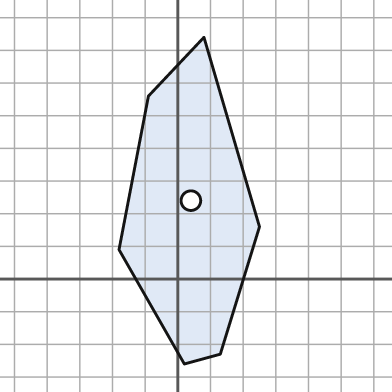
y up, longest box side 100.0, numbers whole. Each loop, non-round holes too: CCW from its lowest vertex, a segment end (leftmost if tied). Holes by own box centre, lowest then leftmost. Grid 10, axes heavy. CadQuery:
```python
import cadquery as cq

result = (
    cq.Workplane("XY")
    .moveTo(2.0, -26.0)
    .lineTo(13.0, -23.0)
    .lineTo(25.0, 16.0)
    .lineTo(8.0, 74.0)
    .lineTo(-9.0, 56.0)
    .lineTo(-18.0, 9.0)
    .close()
    .moveTo(4.0, 24.0)
    .circle(3.0)
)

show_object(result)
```